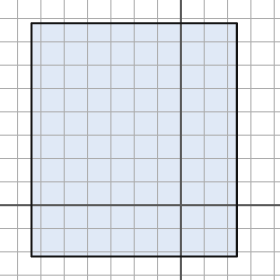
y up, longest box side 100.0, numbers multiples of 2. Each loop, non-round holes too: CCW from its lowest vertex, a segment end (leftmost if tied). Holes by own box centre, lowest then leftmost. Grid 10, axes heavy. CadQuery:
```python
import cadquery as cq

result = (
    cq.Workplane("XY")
    .moveTo(-64.0, -22.0)
    .lineTo(24.0, -22.0)
    .lineTo(24.0, 78.0)
    .lineTo(-64.0, 78.0)
    .close()
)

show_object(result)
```